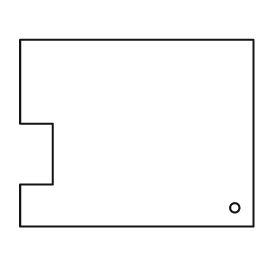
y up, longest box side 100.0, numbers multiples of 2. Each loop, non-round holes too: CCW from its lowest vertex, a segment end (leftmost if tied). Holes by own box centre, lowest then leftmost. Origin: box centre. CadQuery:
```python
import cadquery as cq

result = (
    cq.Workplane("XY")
    .moveTo(-50.0, -40.0)
    .lineTo(50.0, -40.0)
    .lineTo(50.0, 40.0)
    .lineTo(-50.0, 40.0)
    .lineTo(-50.0, 4.0)
    .lineTo(-36.0, 4.0)
    .lineTo(-36.0, -22.0)
    .lineTo(-50.0, -22.0)
    .close()
    .moveTo(42.0, -32.0)
    .circle(2.0)
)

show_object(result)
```